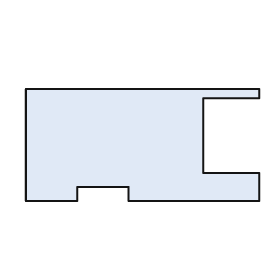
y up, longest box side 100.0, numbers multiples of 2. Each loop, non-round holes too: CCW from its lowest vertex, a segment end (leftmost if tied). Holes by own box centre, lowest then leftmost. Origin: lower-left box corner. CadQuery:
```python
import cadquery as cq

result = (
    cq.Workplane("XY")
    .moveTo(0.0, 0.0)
    .lineTo(22.0, 0.0)
    .lineTo(22.0, 6.0)
    .lineTo(44.0, 6.0)
    .lineTo(44.0, 0.0)
    .lineTo(100.0, 0.0)
    .lineTo(100.0, 12.0)
    .lineTo(76.0, 12.0)
    .lineTo(76.0, 44.0)
    .lineTo(100.0, 44.0)
    .lineTo(100.0, 48.0)
    .lineTo(0.0, 48.0)
    .close()
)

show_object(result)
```